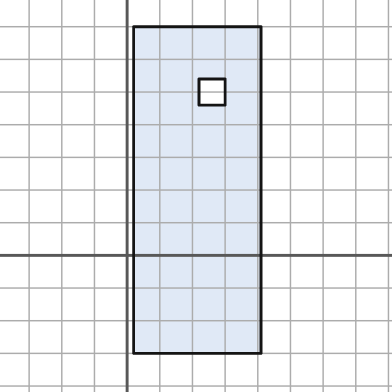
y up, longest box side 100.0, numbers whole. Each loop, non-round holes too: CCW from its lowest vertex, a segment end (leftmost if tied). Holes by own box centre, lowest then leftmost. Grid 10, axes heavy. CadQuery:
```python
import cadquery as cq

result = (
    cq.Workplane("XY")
    .moveTo(2.0, -30.0)
    .lineTo(41.0, -30.0)
    .lineTo(41.0, 70.0)
    .lineTo(2.0, 70.0)
    .close()
    .moveTo(22.0, 46.0)
    .lineTo(30.0, 46.0)
    .lineTo(30.0, 54.0)
    .lineTo(22.0, 54.0)
    .close()
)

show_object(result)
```